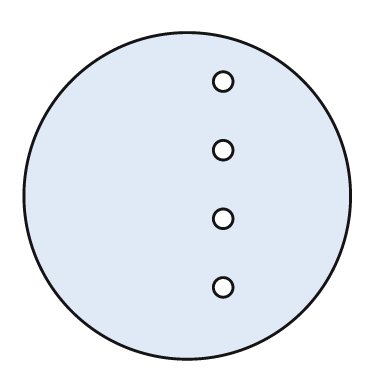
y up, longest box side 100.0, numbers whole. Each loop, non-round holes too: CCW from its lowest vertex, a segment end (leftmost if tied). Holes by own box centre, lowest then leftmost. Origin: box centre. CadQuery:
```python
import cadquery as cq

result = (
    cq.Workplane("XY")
    .moveTo(0.0, 0.0)
    .circle(50.0)
    .moveTo(11.0, -28.0)
    .circle(3.0)
    .moveTo(11.0, -7.0)
    .circle(3.0)
    .moveTo(11.0, 14.0)
    .circle(3.0)
    .moveTo(11.0, 35.0)
    .circle(3.0)
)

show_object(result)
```